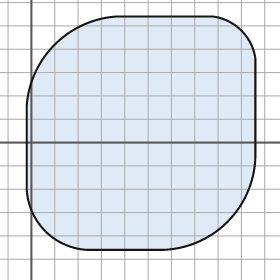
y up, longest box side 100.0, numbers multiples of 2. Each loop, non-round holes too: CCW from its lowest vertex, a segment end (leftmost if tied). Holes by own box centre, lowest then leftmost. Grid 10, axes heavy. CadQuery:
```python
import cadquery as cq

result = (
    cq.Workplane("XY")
    .moveTo(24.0, -46.0)
    .lineTo(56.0, -46.0)
    .threePointArc((84.0, -34.0), (96.0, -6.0))
    .lineTo(96.0, 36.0)
    .threePointArc((90.0, 48.0), (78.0, 54.0))
    .lineTo(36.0, 54.0)
    .threePointArc((10.0, 42.0), (-2.0, 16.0))
    .lineTo(-2.0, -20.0)
    .threePointArc((6.0, -38.0), (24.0, -46.0))
    .close()
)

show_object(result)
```